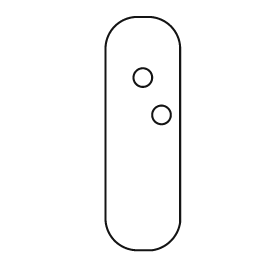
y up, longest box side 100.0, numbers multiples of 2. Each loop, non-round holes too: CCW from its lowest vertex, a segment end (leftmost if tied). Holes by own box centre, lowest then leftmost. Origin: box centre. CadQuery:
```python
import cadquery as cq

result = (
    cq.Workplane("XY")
    .moveTo(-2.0, -50.0)
    .lineTo(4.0, -50.0)
    .threePointArc((12.0, -46.0), (16.0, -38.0))
    .lineTo(16.0, 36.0)
    .threePointArc((12.0, 46.0), (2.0, 50.0))
    .lineTo(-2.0, 50.0)
    .threePointArc((-12.0, 46.0), (-16.0, 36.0))
    .lineTo(-16.0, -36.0)
    .threePointArc((-12.0, -46.0), (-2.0, -50.0))
    .close()
    .moveTo(8.0, 8.0)
    .circle(4.0)
    .moveTo(0.0, 24.0)
    .circle(4.0)
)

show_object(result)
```